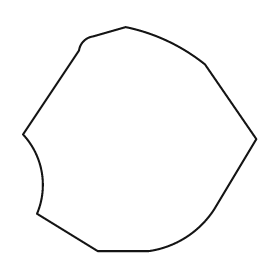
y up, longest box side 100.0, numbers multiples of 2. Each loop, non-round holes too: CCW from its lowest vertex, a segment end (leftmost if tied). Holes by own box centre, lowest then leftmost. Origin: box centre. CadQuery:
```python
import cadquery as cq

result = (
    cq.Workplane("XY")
    .moveTo(-18.0, -48.0)
    .lineTo(4.0, -48.0)
    .threePointArc((20.0, -42.0), (32.0, -30.0))
    .lineTo(50.0, 0.0)
    .lineTo(28.0, 32.0)
    .threePointArc((12.0, 42.0), (-6.0, 48.0))
    .lineTo(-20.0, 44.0)
    .threePointArc((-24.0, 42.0), (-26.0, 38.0))
    .lineTo(-50.0, 2.0)
    .threePointArc((-42.0, -14.0), (-44.0, -32.0))
    .close()
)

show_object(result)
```